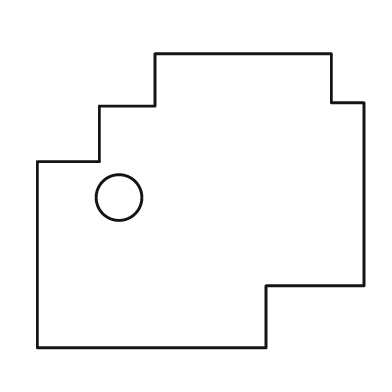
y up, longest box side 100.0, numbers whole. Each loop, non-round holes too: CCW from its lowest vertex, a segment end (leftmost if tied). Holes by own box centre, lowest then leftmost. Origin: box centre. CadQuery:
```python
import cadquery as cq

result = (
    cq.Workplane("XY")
    .moveTo(-50.0, -45.0)
    .lineTo(20.0, -45.0)
    .lineTo(20.0, -26.0)
    .lineTo(50.0, -26.0)
    .lineTo(50.0, 30.0)
    .lineTo(40.0, 30.0)
    .lineTo(40.0, 45.0)
    .lineTo(-14.0, 45.0)
    .lineTo(-14.0, 29.0)
    .lineTo(-31.0, 29.0)
    .lineTo(-31.0, 12.0)
    .lineTo(-50.0, 12.0)
    .close()
    .moveTo(-25.0, 1.0)
    .circle(7.0)
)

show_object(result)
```